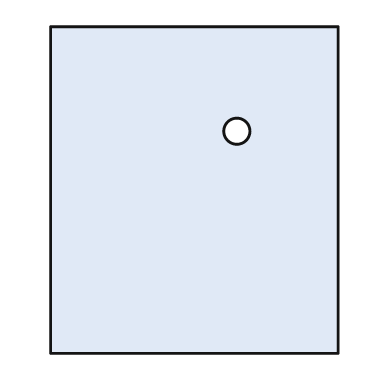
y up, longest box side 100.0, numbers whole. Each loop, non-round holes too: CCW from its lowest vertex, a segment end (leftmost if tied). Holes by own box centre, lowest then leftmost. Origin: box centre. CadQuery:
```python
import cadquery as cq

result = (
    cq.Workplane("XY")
    .moveTo(-44.0, -50.0)
    .lineTo(44.0, -50.0)
    .lineTo(44.0, 50.0)
    .lineTo(-44.0, 50.0)
    .close()
    .moveTo(13.0, 18.0)
    .circle(4.0)
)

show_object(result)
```